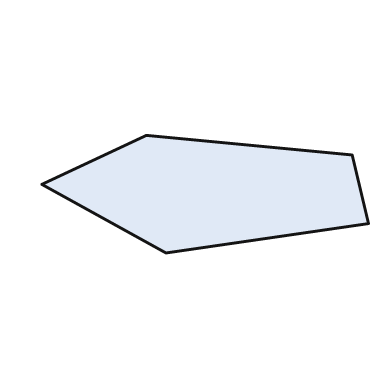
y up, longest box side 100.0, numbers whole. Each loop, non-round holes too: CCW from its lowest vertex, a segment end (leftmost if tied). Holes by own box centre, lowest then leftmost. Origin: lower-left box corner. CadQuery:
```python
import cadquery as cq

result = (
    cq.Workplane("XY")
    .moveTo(38.0, 0.0)
    .lineTo(100.0, 9.0)
    .lineTo(95.0, 30.0)
    .lineTo(32.0, 36.0)
    .lineTo(0.0, 21.0)
    .close()
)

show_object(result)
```